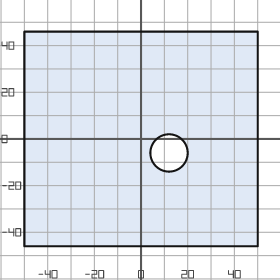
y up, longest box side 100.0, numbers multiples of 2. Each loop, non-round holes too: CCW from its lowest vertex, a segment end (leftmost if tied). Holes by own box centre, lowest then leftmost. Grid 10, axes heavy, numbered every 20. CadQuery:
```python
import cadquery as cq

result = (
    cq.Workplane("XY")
    .moveTo(-50.0, -46.0)
    .lineTo(50.0, -46.0)
    .lineTo(50.0, 46.0)
    .lineTo(-50.0, 46.0)
    .close()
    .moveTo(12.0, -6.0)
    .circle(8.0)
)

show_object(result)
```